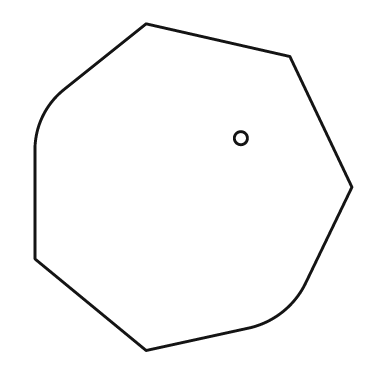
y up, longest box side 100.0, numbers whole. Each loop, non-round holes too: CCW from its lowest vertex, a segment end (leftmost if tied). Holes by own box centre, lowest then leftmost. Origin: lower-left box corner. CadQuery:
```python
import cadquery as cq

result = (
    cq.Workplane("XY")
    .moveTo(34.0, 0.0)
    .lineTo(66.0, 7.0)
    .threePointArc((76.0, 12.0), (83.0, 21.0))
    .lineTo(97.0, 50.0)
    .lineTo(78.0, 90.0)
    .lineTo(34.0, 100.0)
    .lineTo(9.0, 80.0)
    .threePointArc((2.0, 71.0), (0.0, 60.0))
    .lineTo(0.0, 28.0)
    .close()
    .moveTo(63.0, 65.0)
    .circle(2.0)
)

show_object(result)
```